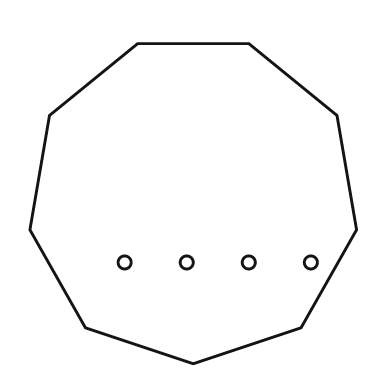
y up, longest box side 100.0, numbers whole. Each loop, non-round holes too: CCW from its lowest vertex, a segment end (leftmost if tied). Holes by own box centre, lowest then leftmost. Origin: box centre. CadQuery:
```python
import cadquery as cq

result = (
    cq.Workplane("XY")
    .moveTo(0.0, -49.0)
    .lineTo(33.0, -38.0)
    .lineTo(50.0, -8.0)
    .lineTo(44.0, 27.0)
    .lineTo(17.0, 49.0)
    .lineTo(-17.0, 49.0)
    .lineTo(-44.0, 27.0)
    .lineTo(-50.0, -8.0)
    .lineTo(-33.0, -38.0)
    .close()
    .moveTo(-21.0, -18.0)
    .circle(2.0)
    .moveTo(-2.0, -18.0)
    .circle(2.0)
    .moveTo(17.0, -18.0)
    .circle(2.0)
    .moveTo(36.0, -18.0)
    .circle(2.0)
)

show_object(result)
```